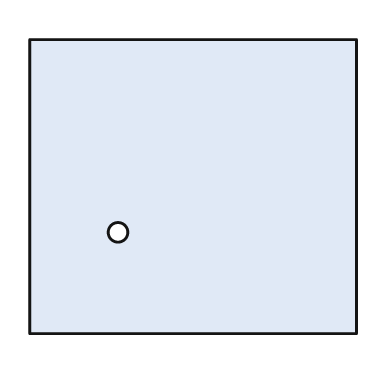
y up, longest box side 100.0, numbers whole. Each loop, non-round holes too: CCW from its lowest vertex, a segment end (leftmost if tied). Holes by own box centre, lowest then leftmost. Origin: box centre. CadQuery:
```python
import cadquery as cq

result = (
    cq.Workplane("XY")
    .moveTo(-50.0, -45.0)
    .lineTo(50.0, -45.0)
    .lineTo(50.0, 45.0)
    .lineTo(-50.0, 45.0)
    .close()
    .moveTo(-23.0, -14.0)
    .circle(3.0)
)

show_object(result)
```